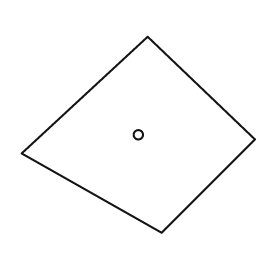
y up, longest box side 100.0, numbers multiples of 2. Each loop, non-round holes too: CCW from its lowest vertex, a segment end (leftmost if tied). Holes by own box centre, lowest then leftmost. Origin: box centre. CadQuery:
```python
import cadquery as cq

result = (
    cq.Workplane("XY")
    .moveTo(10.0, -42.0)
    .lineTo(50.0, -2.0)
    .lineTo(4.0, 42.0)
    .lineTo(-50.0, -8.0)
    .close()
    .moveTo(0.0, 0.0)
    .circle(2.0)
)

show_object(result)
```